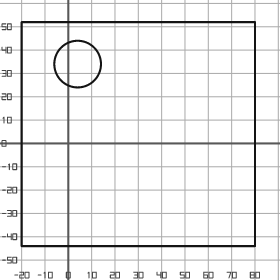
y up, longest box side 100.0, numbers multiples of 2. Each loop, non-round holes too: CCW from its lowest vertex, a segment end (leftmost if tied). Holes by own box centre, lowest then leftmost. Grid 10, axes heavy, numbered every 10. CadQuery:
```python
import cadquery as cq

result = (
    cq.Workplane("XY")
    .moveTo(-20.0, -44.0)
    .lineTo(80.0, -44.0)
    .lineTo(80.0, 52.0)
    .lineTo(-20.0, 52.0)
    .close()
    .moveTo(4.0, 34.0)
    .circle(10.0)
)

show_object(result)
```